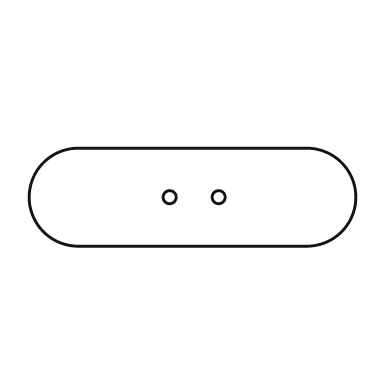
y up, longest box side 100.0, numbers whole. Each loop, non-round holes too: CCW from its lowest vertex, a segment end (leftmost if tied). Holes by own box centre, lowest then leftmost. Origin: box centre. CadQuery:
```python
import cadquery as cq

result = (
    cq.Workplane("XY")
    .moveTo(-35.0, -15.0)
    .lineTo(35.0, -15.0)
    .threePointArc((50.0, 0.0), (35.0, 15.0))
    .lineTo(-35.0, 15.0)
    .threePointArc((-50.0, 0.0), (-35.0, -15.0))
    .close()
    .moveTo(-7.0, 0.0)
    .circle(2.0)
    .moveTo(8.0, 0.0)
    .circle(2.0)
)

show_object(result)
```